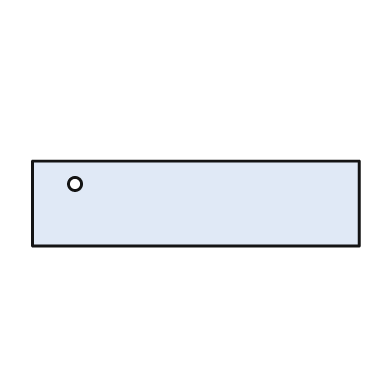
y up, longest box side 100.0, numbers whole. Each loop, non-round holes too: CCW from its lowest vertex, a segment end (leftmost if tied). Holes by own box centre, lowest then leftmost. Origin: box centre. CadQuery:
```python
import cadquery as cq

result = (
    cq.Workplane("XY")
    .moveTo(-50.0, -13.0)
    .lineTo(50.0, -13.0)
    .lineTo(50.0, 13.0)
    .lineTo(-50.0, 13.0)
    .close()
    .moveTo(-37.0, 6.0)
    .circle(2.0)
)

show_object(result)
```